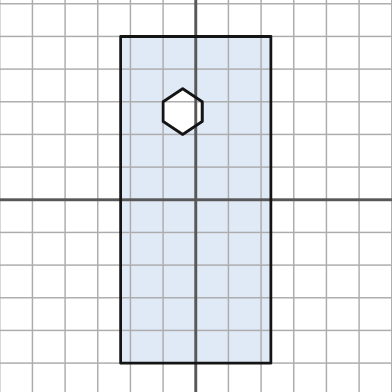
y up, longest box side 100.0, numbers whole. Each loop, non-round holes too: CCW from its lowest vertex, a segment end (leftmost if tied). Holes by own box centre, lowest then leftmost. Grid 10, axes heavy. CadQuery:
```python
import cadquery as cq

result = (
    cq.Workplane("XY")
    .moveTo(-23.0, -50.0)
    .lineTo(23.0, -50.0)
    .lineTo(23.0, 50.0)
    .lineTo(-23.0, 50.0)
    .close()
    .moveTo(-4.0, 20.0)
    .lineTo(2.0, 24.0)
    .lineTo(2.0, 30.0)
    .lineTo(-4.0, 34.0)
    .lineTo(-10.0, 30.0)
    .lineTo(-10.0, 24.0)
    .close()
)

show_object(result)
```